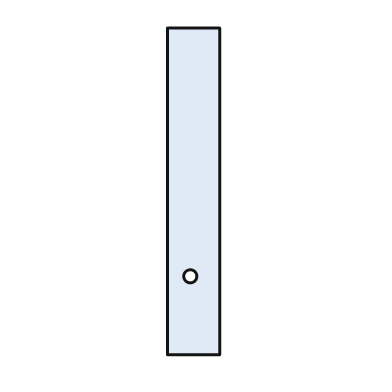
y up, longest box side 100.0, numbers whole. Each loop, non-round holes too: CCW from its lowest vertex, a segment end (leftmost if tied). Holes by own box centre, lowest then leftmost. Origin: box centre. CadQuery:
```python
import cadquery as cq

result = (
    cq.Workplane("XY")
    .moveTo(-8.0, -50.0)
    .lineTo(8.0, -50.0)
    .lineTo(8.0, 50.0)
    .lineTo(-8.0, 50.0)
    .close()
    .moveTo(-1.0, -26.0)
    .circle(2.0)
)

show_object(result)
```